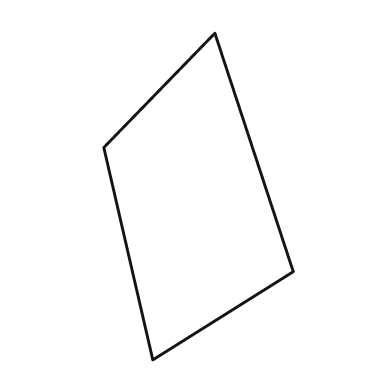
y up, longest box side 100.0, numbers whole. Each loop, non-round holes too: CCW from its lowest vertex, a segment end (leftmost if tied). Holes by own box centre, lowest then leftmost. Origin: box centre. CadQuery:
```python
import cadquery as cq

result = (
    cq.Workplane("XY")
    .moveTo(-14.0, -50.0)
    .lineTo(29.0, -23.0)
    .lineTo(5.0, 50.0)
    .lineTo(-29.0, 15.0)
    .close()
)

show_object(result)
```